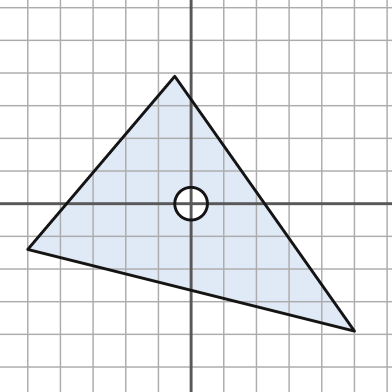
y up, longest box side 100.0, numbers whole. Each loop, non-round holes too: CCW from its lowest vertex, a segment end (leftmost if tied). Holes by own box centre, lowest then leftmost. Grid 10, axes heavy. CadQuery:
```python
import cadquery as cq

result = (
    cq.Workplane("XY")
    .moveTo(50.0, -39.0)
    .lineTo(-5.0, 39.0)
    .lineTo(-50.0, -14.0)
    .close()
    .moveTo(0.0, 0.0)
    .circle(5.0)
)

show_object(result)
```